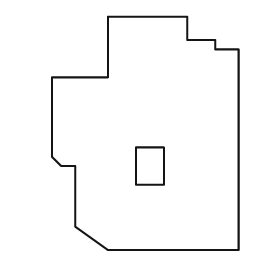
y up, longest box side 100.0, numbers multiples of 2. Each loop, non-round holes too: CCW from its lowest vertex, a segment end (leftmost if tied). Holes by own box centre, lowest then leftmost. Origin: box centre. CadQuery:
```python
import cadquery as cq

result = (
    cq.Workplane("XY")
    .moveTo(-16.0, -50.0)
    .lineTo(40.0, -50.0)
    .lineTo(40.0, 36.0)
    .lineTo(30.0, 36.0)
    .lineTo(30.0, 40.0)
    .lineTo(18.0, 40.0)
    .lineTo(18.0, 50.0)
    .lineTo(-16.0, 50.0)
    .lineTo(-16.0, 24.0)
    .lineTo(-40.0, 24.0)
    .lineTo(-40.0, -10.0)
    .lineTo(-36.0, -14.0)
    .lineTo(-30.0, -14.0)
    .lineTo(-30.0, -40.0)
    .close()
    .moveTo(-4.0, -22.0)
    .lineTo(8.0, -22.0)
    .lineTo(8.0, -6.0)
    .lineTo(-4.0, -6.0)
    .close()
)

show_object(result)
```